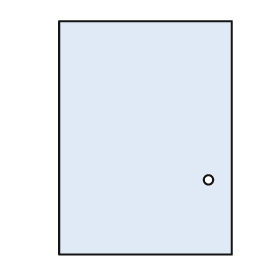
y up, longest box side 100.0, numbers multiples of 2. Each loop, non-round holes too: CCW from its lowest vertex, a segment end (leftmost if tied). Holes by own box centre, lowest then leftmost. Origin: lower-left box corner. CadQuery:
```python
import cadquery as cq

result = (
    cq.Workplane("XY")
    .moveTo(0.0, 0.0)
    .lineTo(74.0, 0.0)
    .lineTo(74.0, 100.0)
    .lineTo(0.0, 100.0)
    .close()
    .moveTo(64.0, 32.0)
    .circle(2.0)
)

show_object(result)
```